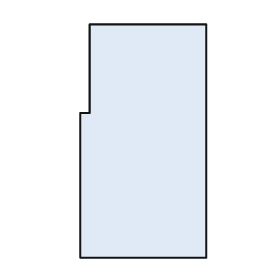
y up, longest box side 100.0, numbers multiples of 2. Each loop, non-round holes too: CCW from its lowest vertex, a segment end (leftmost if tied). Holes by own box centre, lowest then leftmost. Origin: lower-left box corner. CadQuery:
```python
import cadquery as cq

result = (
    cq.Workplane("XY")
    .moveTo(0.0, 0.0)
    .lineTo(54.0, 0.0)
    .lineTo(54.0, 100.0)
    .lineTo(4.0, 100.0)
    .lineTo(4.0, 62.0)
    .lineTo(0.0, 62.0)
    .close()
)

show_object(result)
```